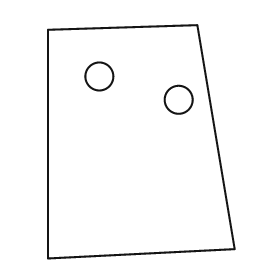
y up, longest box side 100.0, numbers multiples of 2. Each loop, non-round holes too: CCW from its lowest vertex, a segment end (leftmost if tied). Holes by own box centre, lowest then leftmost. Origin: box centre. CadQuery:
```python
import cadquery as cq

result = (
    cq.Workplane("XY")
    .moveTo(-40.0, -50.0)
    .lineTo(40.0, -46.0)
    .lineTo(24.0, 50.0)
    .lineTo(-40.0, 48.0)
    .close()
    .moveTo(16.0, 18.0)
    .circle(6.0)
    .moveTo(-18.0, 28.0)
    .circle(6.0)
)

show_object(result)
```